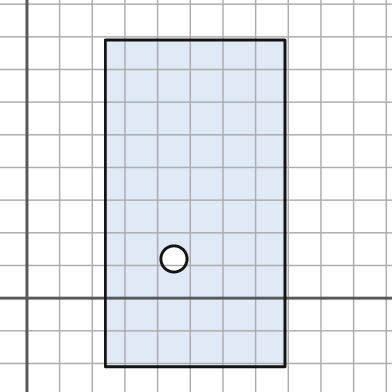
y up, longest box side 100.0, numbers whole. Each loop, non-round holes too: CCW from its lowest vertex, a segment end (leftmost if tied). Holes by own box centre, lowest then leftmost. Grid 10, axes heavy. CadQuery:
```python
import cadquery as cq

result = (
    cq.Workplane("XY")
    .moveTo(24.0, -21.0)
    .lineTo(79.0, -21.0)
    .lineTo(79.0, 79.0)
    .lineTo(24.0, 79.0)
    .close()
    .moveTo(45.0, 12.0)
    .circle(4.0)
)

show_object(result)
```